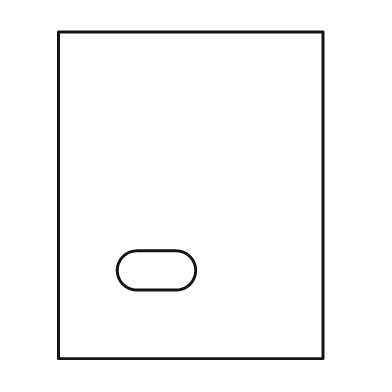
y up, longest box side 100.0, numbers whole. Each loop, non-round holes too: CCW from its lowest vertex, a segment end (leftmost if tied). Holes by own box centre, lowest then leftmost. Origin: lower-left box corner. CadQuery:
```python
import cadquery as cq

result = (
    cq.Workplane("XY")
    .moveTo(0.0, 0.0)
    .lineTo(81.0, 0.0)
    .lineTo(81.0, 100.0)
    .lineTo(0.0, 100.0)
    .close()
    .moveTo(24.0, 21.0)
    .lineTo(36.0, 21.0)
    .threePointArc((42.0, 27.0), (36.0, 33.0))
    .lineTo(24.0, 33.0)
    .threePointArc((18.0, 27.0), (24.0, 21.0))
    .close()
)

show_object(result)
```